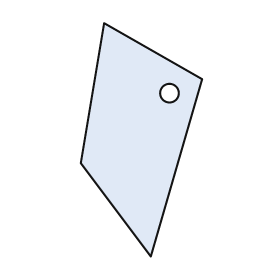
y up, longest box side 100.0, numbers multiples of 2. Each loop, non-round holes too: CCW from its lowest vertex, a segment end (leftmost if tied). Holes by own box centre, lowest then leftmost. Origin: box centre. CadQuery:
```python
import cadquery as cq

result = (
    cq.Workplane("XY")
    .moveTo(4.0, -50.0)
    .lineTo(26.0, 26.0)
    .lineTo(-16.0, 50.0)
    .lineTo(-26.0, -10.0)
    .close()
    .moveTo(12.0, 20.0)
    .circle(4.0)
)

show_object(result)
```